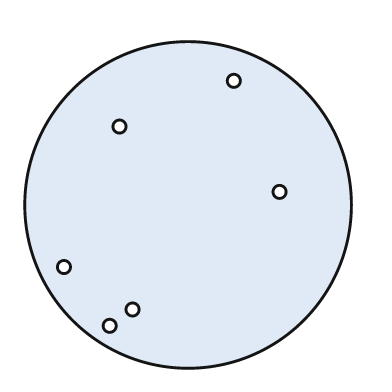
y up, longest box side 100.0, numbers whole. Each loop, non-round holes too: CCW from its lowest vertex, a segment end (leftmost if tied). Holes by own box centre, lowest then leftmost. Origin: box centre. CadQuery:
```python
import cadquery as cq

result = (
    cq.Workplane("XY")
    .moveTo(0.0, 0.0)
    .circle(50.0)
    .moveTo(-24.0, -37.0)
    .circle(2.0)
    .moveTo(-17.0, -32.0)
    .circle(2.0)
    .moveTo(-38.0, -19.0)
    .circle(2.0)
    .moveTo(28.0, 4.0)
    .circle(2.0)
    .moveTo(-21.0, 24.0)
    .circle(2.0)
    .moveTo(14.0, 38.0)
    .circle(2.0)
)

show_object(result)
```